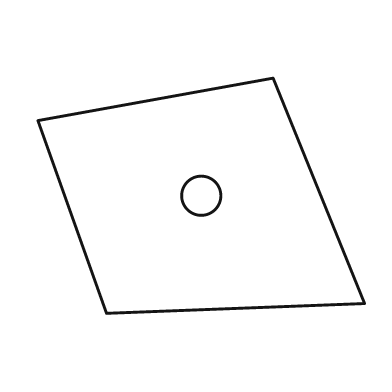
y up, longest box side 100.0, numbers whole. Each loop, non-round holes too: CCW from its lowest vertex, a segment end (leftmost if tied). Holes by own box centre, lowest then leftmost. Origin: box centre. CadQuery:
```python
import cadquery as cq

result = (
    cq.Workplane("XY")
    .moveTo(-29.0, -36.0)
    .lineTo(50.0, -33.0)
    .lineTo(22.0, 36.0)
    .lineTo(-50.0, 23.0)
    .close()
    .moveTo(0.0, 0.0)
    .circle(6.0)
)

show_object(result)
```